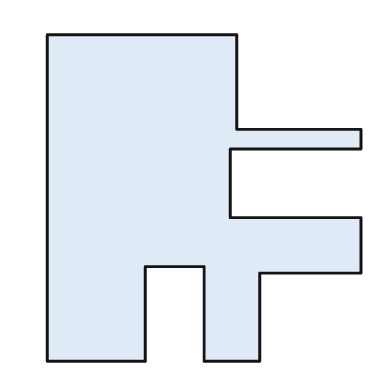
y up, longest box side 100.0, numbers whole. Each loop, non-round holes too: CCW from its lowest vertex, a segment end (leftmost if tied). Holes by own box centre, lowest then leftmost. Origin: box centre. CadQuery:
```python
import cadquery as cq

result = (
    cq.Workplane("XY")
    .moveTo(-48.0, -50.0)
    .lineTo(-18.0, -50.0)
    .lineTo(-18.0, -21.0)
    .lineTo(0.0, -21.0)
    .lineTo(0.0, -50.0)
    .lineTo(17.0, -50.0)
    .lineTo(17.0, -23.0)
    .lineTo(48.0, -23.0)
    .lineTo(48.0, -6.0)
    .lineTo(8.0, -6.0)
    .lineTo(8.0, 15.0)
    .lineTo(48.0, 15.0)
    .lineTo(48.0, 21.0)
    .lineTo(10.0, 21.0)
    .lineTo(10.0, 50.0)
    .lineTo(-48.0, 50.0)
    .close()
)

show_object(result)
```